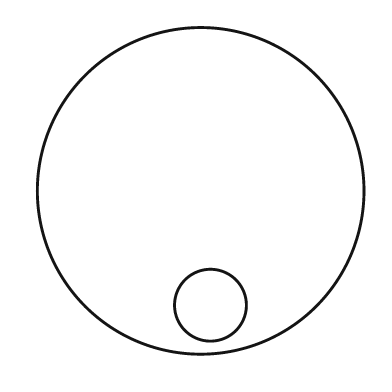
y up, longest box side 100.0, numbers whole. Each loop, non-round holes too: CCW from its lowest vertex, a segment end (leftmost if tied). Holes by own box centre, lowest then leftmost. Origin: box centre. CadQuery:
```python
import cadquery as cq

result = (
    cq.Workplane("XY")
    .moveTo(0.0, 0.0)
    .circle(50.0)
    .moveTo(3.0, -35.0)
    .circle(11.0)
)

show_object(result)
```